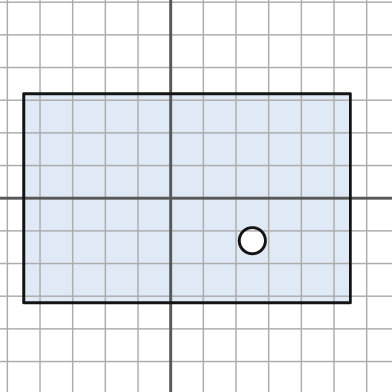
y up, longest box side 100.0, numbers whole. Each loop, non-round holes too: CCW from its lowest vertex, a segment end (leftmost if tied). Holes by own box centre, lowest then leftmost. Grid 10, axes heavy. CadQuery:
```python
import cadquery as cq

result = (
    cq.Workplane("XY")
    .moveTo(-45.0, -32.0)
    .lineTo(55.0, -32.0)
    .lineTo(55.0, 32.0)
    .lineTo(-45.0, 32.0)
    .close()
    .moveTo(25.0, -13.0)
    .circle(4.0)
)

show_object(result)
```